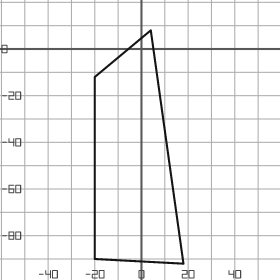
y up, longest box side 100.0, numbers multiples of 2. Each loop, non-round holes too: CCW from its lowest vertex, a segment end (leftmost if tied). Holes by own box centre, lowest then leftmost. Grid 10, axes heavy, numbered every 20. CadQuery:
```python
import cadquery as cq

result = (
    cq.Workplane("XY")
    .moveTo(18.0, -92.0)
    .lineTo(4.0, 8.0)
    .lineTo(-20.0, -12.0)
    .lineTo(-20.0, -90.0)
    .close()
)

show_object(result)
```